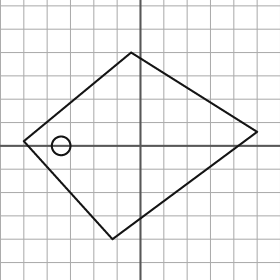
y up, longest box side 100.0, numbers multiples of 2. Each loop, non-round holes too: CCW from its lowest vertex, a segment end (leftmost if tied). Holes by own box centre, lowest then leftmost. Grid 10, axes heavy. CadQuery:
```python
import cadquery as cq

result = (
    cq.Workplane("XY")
    .moveTo(-12.0, -40.0)
    .lineTo(50.0, 6.0)
    .lineTo(-4.0, 40.0)
    .lineTo(-50.0, 2.0)
    .close()
    .moveTo(-34.0, 0.0)
    .circle(4.0)
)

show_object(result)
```